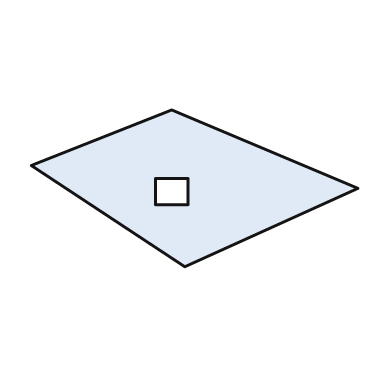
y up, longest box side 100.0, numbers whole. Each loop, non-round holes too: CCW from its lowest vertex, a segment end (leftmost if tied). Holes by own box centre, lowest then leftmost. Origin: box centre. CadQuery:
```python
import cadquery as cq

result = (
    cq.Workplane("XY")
    .moveTo(-3.0, -24.0)
    .lineTo(50.0, 0.0)
    .lineTo(-7.0, 24.0)
    .lineTo(-50.0, 7.0)
    .close()
    .moveTo(-12.0, -5.0)
    .lineTo(-2.0, -5.0)
    .lineTo(-2.0, 3.0)
    .lineTo(-12.0, 3.0)
    .close()
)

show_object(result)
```